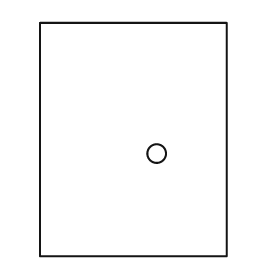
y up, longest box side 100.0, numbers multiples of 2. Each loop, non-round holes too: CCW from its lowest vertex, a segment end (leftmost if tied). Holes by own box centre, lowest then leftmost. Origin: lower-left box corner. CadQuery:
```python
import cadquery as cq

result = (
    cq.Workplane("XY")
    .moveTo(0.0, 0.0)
    .lineTo(80.0, 0.0)
    .lineTo(80.0, 100.0)
    .lineTo(0.0, 100.0)
    .close()
    .moveTo(50.0, 44.0)
    .circle(4.0)
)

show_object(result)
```